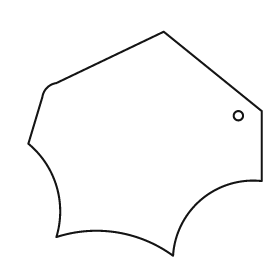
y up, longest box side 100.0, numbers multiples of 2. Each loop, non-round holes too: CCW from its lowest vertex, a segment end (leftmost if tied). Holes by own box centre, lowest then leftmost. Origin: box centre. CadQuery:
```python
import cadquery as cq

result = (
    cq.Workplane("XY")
    .moveTo(12.0, -48.0)
    .threePointArc((24.0, -24.0), (50.0, -16.0))
    .lineTo(50.0, 14.0)
    .lineTo(8.0, 48.0)
    .lineTo(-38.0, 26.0)
    .threePointArc((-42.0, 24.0), (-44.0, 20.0))
    .lineTo(-50.0, 0.0)
    .threePointArc((-38.0, -18.0), (-38.0, -40.0))
    .threePointArc((-12.0, -38.0), (12.0, -48.0))
    .close()
    .moveTo(40.0, 12.0)
    .circle(2.0)
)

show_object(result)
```